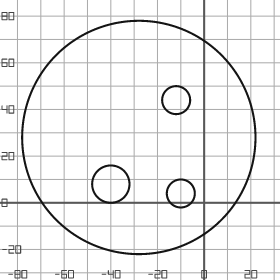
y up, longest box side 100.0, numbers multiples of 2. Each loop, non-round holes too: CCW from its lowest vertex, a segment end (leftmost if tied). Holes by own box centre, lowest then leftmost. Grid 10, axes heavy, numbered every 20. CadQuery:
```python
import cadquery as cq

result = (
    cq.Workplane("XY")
    .moveTo(-28.0, 28.0)
    .circle(50.0)
    .moveTo(-10.0, 4.0)
    .circle(6.0)
    .moveTo(-40.0, 8.0)
    .circle(8.0)
    .moveTo(-12.0, 44.0)
    .circle(6.0)
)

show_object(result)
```